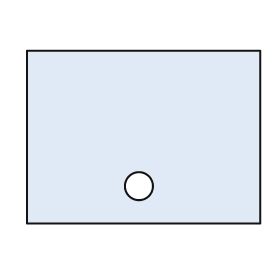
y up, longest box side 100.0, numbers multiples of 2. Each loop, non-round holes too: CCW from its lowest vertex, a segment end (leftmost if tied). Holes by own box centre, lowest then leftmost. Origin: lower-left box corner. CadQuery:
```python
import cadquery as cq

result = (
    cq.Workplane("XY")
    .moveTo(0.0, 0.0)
    .lineTo(100.0, 0.0)
    .lineTo(100.0, 74.0)
    .lineTo(0.0, 74.0)
    .close()
    .moveTo(48.0, 16.0)
    .circle(6.0)
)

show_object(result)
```